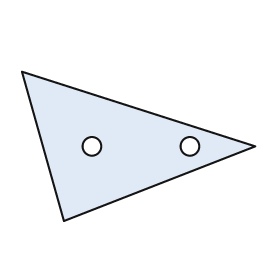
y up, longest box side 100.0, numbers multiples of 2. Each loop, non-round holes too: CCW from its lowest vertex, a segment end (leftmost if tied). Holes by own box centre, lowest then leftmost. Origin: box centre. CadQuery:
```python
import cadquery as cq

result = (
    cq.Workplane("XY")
    .moveTo(-32.0, -32.0)
    .lineTo(50.0, 0.0)
    .lineTo(-50.0, 32.0)
    .close()
    .moveTo(-20.0, 0.0)
    .circle(4.0)
    .moveTo(22.0, 0.0)
    .circle(4.0)
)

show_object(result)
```